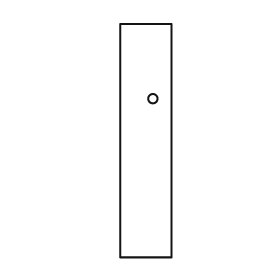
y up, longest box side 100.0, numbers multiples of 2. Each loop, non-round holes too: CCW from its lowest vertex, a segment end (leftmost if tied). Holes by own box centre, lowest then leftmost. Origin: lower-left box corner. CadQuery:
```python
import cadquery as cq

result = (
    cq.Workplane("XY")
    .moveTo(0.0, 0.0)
    .lineTo(22.0, 0.0)
    .lineTo(22.0, 100.0)
    .lineTo(0.0, 100.0)
    .close()
    .moveTo(14.0, 68.0)
    .circle(2.0)
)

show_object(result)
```